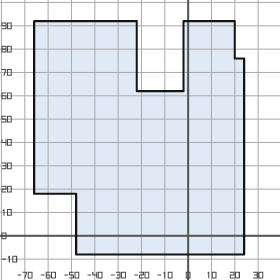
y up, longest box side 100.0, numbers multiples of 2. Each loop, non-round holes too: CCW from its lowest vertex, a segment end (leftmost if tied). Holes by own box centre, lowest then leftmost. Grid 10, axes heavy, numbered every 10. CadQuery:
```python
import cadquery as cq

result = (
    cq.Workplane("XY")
    .moveTo(-48.0, -8.0)
    .lineTo(24.0, -8.0)
    .lineTo(24.0, 76.0)
    .lineTo(20.0, 76.0)
    .lineTo(20.0, 92.0)
    .lineTo(-2.0, 92.0)
    .lineTo(-2.0, 62.0)
    .lineTo(-22.0, 62.0)
    .lineTo(-22.0, 92.0)
    .lineTo(-66.0, 92.0)
    .lineTo(-66.0, 18.0)
    .lineTo(-48.0, 18.0)
    .close()
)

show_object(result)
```